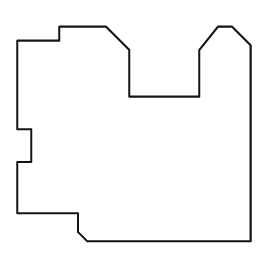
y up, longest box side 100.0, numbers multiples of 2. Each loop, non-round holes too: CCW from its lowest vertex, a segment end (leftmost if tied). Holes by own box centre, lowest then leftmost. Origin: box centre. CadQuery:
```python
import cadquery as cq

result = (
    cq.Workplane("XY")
    .moveTo(-20.0, -46.0)
    .lineTo(50.0, -46.0)
    .lineTo(50.0, 38.0)
    .lineTo(42.0, 46.0)
    .lineTo(36.0, 46.0)
    .lineTo(28.0, 36.0)
    .lineTo(28.0, 16.0)
    .lineTo(-2.0, 16.0)
    .lineTo(-2.0, 36.0)
    .lineTo(-12.0, 46.0)
    .lineTo(-32.0, 46.0)
    .lineTo(-32.0, 40.0)
    .lineTo(-50.0, 40.0)
    .lineTo(-50.0, 2.0)
    .lineTo(-44.0, 2.0)
    .lineTo(-44.0, -12.0)
    .lineTo(-50.0, -12.0)
    .lineTo(-50.0, -34.0)
    .lineTo(-24.0, -34.0)
    .lineTo(-24.0, -42.0)
    .close()
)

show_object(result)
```